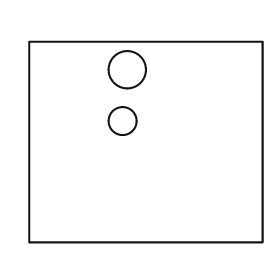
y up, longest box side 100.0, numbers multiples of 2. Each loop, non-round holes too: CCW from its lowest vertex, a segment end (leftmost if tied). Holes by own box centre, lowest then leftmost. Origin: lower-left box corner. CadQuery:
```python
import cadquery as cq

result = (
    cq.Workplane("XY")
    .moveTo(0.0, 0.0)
    .lineTo(100.0, 0.0)
    .lineTo(100.0, 86.0)
    .lineTo(0.0, 86.0)
    .close()
    .moveTo(40.0, 52.0)
    .circle(6.0)
    .moveTo(42.0, 74.0)
    .circle(8.0)
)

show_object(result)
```